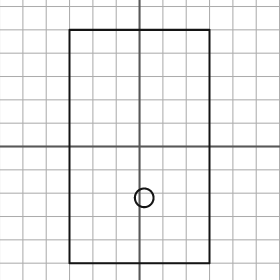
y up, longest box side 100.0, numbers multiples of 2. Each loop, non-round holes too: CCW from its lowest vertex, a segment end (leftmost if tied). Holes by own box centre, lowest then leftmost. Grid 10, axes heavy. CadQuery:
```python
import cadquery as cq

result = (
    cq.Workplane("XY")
    .moveTo(-30.0, -50.0)
    .lineTo(30.0, -50.0)
    .lineTo(30.0, 50.0)
    .lineTo(-30.0, 50.0)
    .close()
    .moveTo(2.0, -22.0)
    .circle(4.0)
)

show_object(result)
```